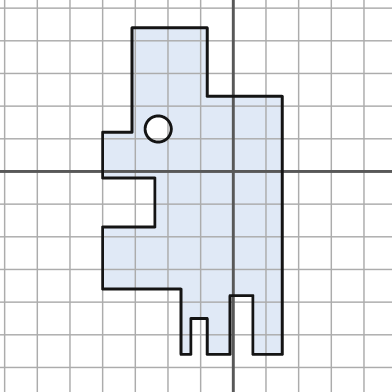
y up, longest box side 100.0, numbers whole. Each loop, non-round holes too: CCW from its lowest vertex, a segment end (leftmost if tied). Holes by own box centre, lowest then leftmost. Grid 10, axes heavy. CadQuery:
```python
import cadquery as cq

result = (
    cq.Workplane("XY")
    .moveTo(-16.0, -56.0)
    .lineTo(-13.0, -56.0)
    .lineTo(-13.0, -45.0)
    .lineTo(-8.0, -45.0)
    .lineTo(-8.0, -56.0)
    .lineTo(-1.0, -56.0)
    .lineTo(-1.0, -38.0)
    .lineTo(6.0, -38.0)
    .lineTo(6.0, -56.0)
    .lineTo(15.0, -56.0)
    .lineTo(15.0, 23.0)
    .lineTo(-8.0, 23.0)
    .lineTo(-8.0, 44.0)
    .lineTo(-31.0, 44.0)
    .lineTo(-31.0, 12.0)
    .lineTo(-40.0, 12.0)
    .lineTo(-40.0, -2.0)
    .lineTo(-24.0, -2.0)
    .lineTo(-24.0, -17.0)
    .lineTo(-40.0, -17.0)
    .lineTo(-40.0, -36.0)
    .lineTo(-16.0, -36.0)
    .close()
    .moveTo(-23.0, 13.0)
    .circle(4.0)
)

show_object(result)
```